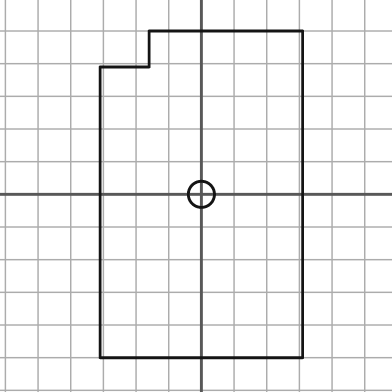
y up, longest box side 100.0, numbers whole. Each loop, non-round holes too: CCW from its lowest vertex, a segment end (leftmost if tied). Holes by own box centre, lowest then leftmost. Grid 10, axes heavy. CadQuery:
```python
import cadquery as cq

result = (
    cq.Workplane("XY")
    .moveTo(-31.0, -50.0)
    .lineTo(31.0, -50.0)
    .lineTo(31.0, 50.0)
    .lineTo(-16.0, 50.0)
    .lineTo(-16.0, 39.0)
    .lineTo(-31.0, 39.0)
    .close()
    .moveTo(0.0, 0.0)
    .circle(4.0)
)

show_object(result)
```